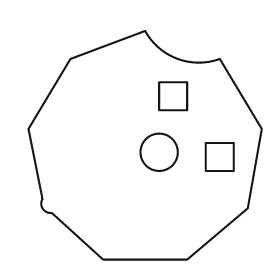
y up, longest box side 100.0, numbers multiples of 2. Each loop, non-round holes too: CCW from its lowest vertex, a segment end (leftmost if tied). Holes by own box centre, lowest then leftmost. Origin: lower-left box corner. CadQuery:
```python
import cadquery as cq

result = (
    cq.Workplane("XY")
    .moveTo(32.0, 0.0)
    .lineTo(68.0, 0.0)
    .lineTo(94.0, 22.0)
    .lineTo(100.0, 56.0)
    .lineTo(82.0, 86.0)
    .threePointArc((64.0, 86.0), (50.0, 98.0))
    .lineTo(18.0, 86.0)
    .lineTo(0.0, 56.0)
    .lineTo(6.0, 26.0)
    .threePointArc((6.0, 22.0), (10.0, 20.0))
    .close()
    .moveTo(76.0, 38.0)
    .lineTo(88.0, 38.0)
    .lineTo(88.0, 50.0)
    .lineTo(76.0, 50.0)
    .close()
    .moveTo(56.0, 46.0)
    .circle(8.0)
    .moveTo(56.0, 64.0)
    .lineTo(68.0, 64.0)
    .lineTo(68.0, 76.0)
    .lineTo(56.0, 76.0)
    .close()
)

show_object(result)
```